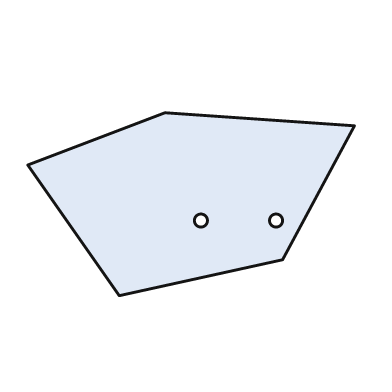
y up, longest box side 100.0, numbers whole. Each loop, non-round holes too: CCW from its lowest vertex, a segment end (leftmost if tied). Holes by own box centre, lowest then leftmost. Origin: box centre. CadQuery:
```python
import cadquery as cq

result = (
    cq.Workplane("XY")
    .moveTo(-22.0, -28.0)
    .lineTo(28.0, -17.0)
    .lineTo(50.0, 24.0)
    .lineTo(-8.0, 28.0)
    .lineTo(-50.0, 12.0)
    .close()
    .moveTo(3.0, -5.0)
    .circle(2.0)
    .moveTo(26.0, -5.0)
    .circle(2.0)
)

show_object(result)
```